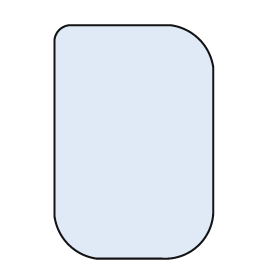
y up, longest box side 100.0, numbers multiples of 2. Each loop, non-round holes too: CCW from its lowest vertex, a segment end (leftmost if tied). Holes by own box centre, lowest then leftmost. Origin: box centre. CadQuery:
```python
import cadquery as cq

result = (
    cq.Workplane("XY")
    .moveTo(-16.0, -50.0)
    .lineTo(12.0, -50.0)
    .threePointArc((28.0, -44.0), (34.0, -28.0))
    .lineTo(34.0, 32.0)
    .threePointArc((28.0, 44.0), (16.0, 50.0))
    .lineTo(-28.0, 50.0)
    .threePointArc((-32.0, 48.0), (-34.0, 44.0))
    .lineTo(-34.0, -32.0)
    .threePointArc((-28.0, -44.0), (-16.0, -50.0))
    .close()
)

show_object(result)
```